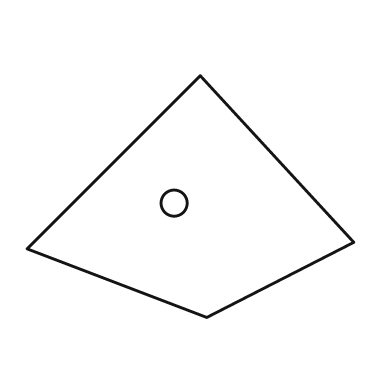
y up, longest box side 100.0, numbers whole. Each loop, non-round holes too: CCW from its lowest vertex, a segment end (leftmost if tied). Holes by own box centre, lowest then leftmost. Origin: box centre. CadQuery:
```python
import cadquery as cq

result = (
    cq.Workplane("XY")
    .moveTo(5.0, -37.0)
    .lineTo(50.0, -14.0)
    .lineTo(3.0, 37.0)
    .lineTo(-50.0, -16.0)
    .close()
    .moveTo(-5.0, -2.0)
    .circle(4.0)
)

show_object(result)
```